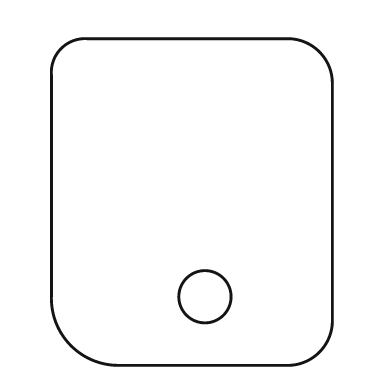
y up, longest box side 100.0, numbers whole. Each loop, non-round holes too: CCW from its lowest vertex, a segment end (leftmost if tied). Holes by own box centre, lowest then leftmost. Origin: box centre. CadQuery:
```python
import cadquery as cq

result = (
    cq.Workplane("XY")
    .moveTo(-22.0, -50.0)
    .lineTo(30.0, -50.0)
    .threePointArc((39.0, -46.0), (43.0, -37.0))
    .lineTo(43.0, 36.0)
    .threePointArc((39.0, 46.0), (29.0, 50.0))
    .lineTo(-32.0, 50.0)
    .threePointArc((-40.0, 47.0), (-43.0, 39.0))
    .lineTo(-43.0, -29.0)
    .threePointArc((-37.0, -44.0), (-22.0, -50.0))
    .close()
    .moveTo(4.0, -29.0)
    .circle(8.0)
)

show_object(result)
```